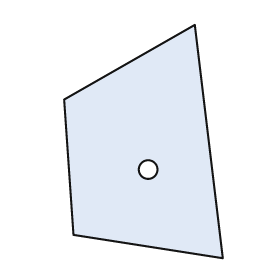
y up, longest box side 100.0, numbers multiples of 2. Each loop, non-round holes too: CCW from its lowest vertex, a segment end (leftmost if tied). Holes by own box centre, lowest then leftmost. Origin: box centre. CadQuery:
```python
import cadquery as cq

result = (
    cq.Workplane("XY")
    .moveTo(34.0, -50.0)
    .lineTo(22.0, 50.0)
    .lineTo(-34.0, 18.0)
    .lineTo(-30.0, -40.0)
    .close()
    .moveTo(2.0, -12.0)
    .circle(4.0)
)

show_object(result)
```